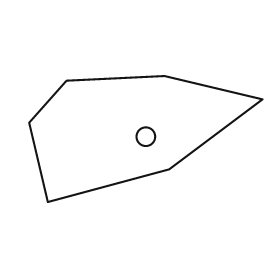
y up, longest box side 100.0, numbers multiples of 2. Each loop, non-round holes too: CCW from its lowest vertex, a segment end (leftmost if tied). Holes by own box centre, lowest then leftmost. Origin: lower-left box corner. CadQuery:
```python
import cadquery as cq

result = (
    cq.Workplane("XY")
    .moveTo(8.0, 0.0)
    .lineTo(60.0, 14.0)
    .lineTo(100.0, 44.0)
    .lineTo(58.0, 54.0)
    .lineTo(16.0, 52.0)
    .lineTo(0.0, 34.0)
    .close()
    .moveTo(50.0, 28.0)
    .circle(4.0)
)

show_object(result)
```